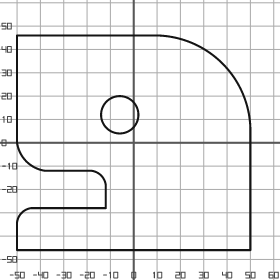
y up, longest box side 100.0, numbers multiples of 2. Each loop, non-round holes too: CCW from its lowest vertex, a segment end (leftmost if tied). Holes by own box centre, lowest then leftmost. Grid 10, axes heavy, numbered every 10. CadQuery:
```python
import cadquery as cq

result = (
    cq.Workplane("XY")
    .moveTo(-50.0, -46.0)
    .lineTo(50.0, -46.0)
    .lineTo(50.0, 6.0)
    .threePointArc((38.0, 34.0), (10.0, 46.0))
    .lineTo(-50.0, 46.0)
    .lineTo(-50.0, 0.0)
    .threePointArc((-46.0, -8.0), (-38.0, -12.0))
    .lineTo(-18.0, -12.0)
    .threePointArc((-14.0, -14.0), (-12.0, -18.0))
    .lineTo(-12.0, -28.0)
    .lineTo(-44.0, -28.0)
    .threePointArc((-48.0, -30.0), (-50.0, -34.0))
    .close()
    .moveTo(-6.0, 12.0)
    .circle(8.0)
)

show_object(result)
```